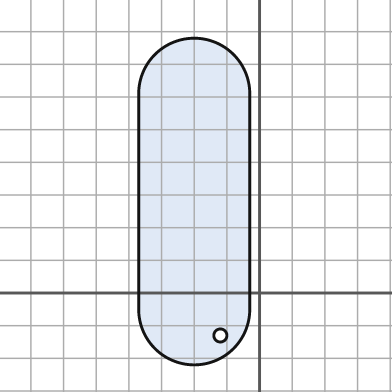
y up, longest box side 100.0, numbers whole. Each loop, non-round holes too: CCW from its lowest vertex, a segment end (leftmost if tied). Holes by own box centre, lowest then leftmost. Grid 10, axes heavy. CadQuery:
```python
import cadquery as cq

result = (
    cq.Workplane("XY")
    .moveTo(-37.0, -5.0)
    .threePointArc((-20.0, -22.0), (-3.0, -5.0))
    .lineTo(-3.0, 61.0)
    .threePointArc((-20.0, 78.0), (-37.0, 61.0))
    .close()
    .moveTo(-12.0, -13.0)
    .circle(2.0)
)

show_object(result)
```